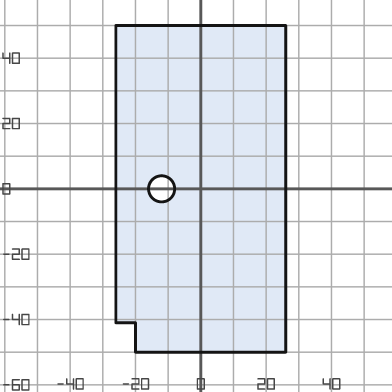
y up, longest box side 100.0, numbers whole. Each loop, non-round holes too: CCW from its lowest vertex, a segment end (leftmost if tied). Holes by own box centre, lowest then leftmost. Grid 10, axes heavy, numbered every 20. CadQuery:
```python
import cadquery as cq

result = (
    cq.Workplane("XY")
    .moveTo(-20.0, -50.0)
    .lineTo(26.0, -50.0)
    .lineTo(26.0, 50.0)
    .lineTo(-26.0, 50.0)
    .lineTo(-26.0, -41.0)
    .lineTo(-20.0, -41.0)
    .close()
    .moveTo(-12.0, 0.0)
    .circle(4.0)
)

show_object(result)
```